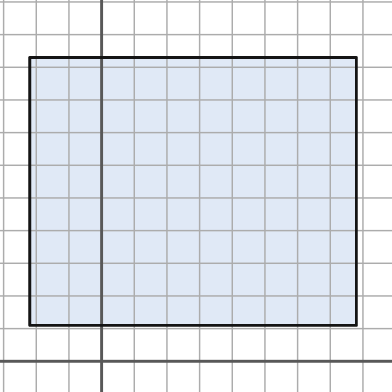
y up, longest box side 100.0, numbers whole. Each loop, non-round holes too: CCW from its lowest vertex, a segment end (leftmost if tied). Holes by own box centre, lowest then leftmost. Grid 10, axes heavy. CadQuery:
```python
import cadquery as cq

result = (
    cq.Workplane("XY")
    .moveTo(-22.0, 11.0)
    .lineTo(78.0, 11.0)
    .lineTo(78.0, 93.0)
    .lineTo(-22.0, 93.0)
    .close()
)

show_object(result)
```